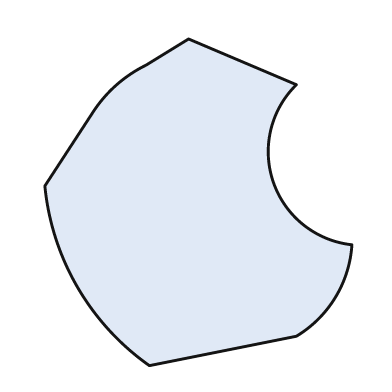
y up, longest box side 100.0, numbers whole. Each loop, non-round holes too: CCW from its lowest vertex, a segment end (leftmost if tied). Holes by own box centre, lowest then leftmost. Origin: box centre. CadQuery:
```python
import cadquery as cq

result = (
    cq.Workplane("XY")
    .moveTo(-15.0, -50.0)
    .lineTo(30.0, -41.0)
    .threePointArc((42.0, -29.0), (47.0, -13.0))
    .threePointArc((23.0, 6.0), (30.0, 36.0))
    .lineTo(-3.0, 50.0)
    .lineTo(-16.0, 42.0)
    .threePointArc((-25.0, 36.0), (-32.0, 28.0))
    .lineTo(-47.0, 5.0)
    .threePointArc((-37.0, -26.0), (-15.0, -50.0))
    .close()
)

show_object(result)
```